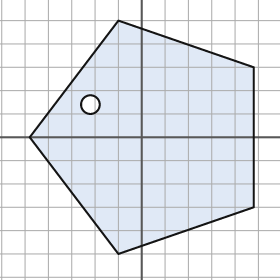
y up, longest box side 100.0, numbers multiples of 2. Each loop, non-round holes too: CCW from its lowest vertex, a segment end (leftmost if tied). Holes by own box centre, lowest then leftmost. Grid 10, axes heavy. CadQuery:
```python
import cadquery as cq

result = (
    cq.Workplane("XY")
    .moveTo(-10.0, -50.0)
    .lineTo(48.0, -30.0)
    .lineTo(48.0, 30.0)
    .lineTo(-10.0, 50.0)
    .lineTo(-48.0, 0.0)
    .close()
    .moveTo(-22.0, 14.0)
    .circle(4.0)
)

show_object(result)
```